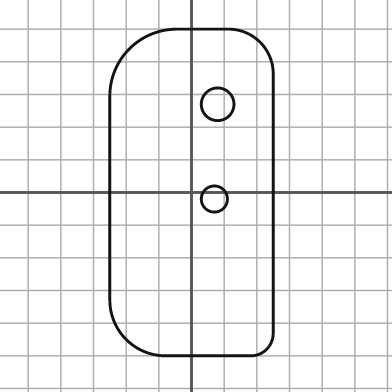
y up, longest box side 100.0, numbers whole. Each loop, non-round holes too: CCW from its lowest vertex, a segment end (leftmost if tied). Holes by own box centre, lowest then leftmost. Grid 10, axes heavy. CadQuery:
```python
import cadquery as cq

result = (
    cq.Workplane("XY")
    .moveTo(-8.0, -50.0)
    .lineTo(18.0, -50.0)
    .threePointArc((23.0, -48.0), (25.0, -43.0))
    .lineTo(25.0, 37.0)
    .threePointArc((21.0, 46.0), (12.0, 50.0))
    .lineTo(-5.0, 50.0)
    .threePointArc((-19.0, 44.0), (-25.0, 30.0))
    .lineTo(-25.0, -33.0)
    .threePointArc((-20.0, -45.0), (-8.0, -50.0))
    .close()
    .moveTo(7.0, -2.0)
    .circle(4.0)
    .moveTo(8.0, 27.0)
    .circle(5.0)
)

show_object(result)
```